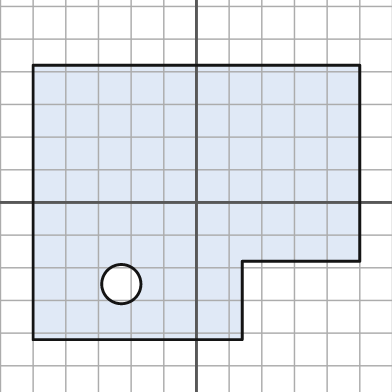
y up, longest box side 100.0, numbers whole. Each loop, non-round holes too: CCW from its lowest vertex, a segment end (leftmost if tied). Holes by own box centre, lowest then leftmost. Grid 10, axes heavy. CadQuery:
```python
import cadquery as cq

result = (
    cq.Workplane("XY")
    .moveTo(-50.0, -42.0)
    .lineTo(14.0, -42.0)
    .lineTo(14.0, -18.0)
    .lineTo(50.0, -18.0)
    .lineTo(50.0, 42.0)
    .lineTo(-50.0, 42.0)
    .close()
    .moveTo(-23.0, -25.0)
    .circle(6.0)
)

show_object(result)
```